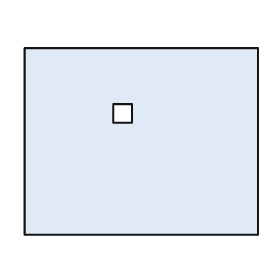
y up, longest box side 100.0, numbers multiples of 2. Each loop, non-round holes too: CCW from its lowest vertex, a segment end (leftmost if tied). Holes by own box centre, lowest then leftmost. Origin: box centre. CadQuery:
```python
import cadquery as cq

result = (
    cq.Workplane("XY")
    .moveTo(-50.0, -40.0)
    .lineTo(50.0, -40.0)
    .lineTo(50.0, 40.0)
    .lineTo(-50.0, 40.0)
    .close()
    .moveTo(-12.0, 8.0)
    .lineTo(-4.0, 8.0)
    .lineTo(-4.0, 16.0)
    .lineTo(-12.0, 16.0)
    .close()
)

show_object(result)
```